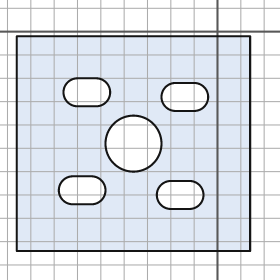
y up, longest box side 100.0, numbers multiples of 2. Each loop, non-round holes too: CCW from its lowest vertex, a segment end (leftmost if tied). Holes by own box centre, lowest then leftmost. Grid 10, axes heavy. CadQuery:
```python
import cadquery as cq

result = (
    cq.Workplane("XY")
    .moveTo(-86.0, -94.0)
    .lineTo(14.0, -94.0)
    .lineTo(14.0, -2.0)
    .lineTo(-86.0, -2.0)
    .close()
    .moveTo(-20.0, -76.0)
    .lineTo(-12.0, -76.0)
    .threePointArc((-6.0, -70.0), (-12.0, -64.0))
    .lineTo(-20.0, -64.0)
    .threePointArc((-26.0, -70.0), (-20.0, -76.0))
    .close()
    .moveTo(-62.0, -74.0)
    .lineTo(-54.0, -74.0)
    .threePointArc((-48.0, -68.0), (-54.0, -62.0))
    .lineTo(-62.0, -62.0)
    .threePointArc((-68.0, -68.0), (-62.0, -74.0))
    .close()
    .moveTo(-36.0, -48.0)
    .circle(12.0)
    .moveTo(-18.0, -34.0)
    .lineTo(-10.0, -34.0)
    .threePointArc((-4.0, -28.0), (-10.0, -22.0))
    .lineTo(-18.0, -22.0)
    .threePointArc((-24.0, -28.0), (-18.0, -34.0))
    .close()
    .moveTo(-60.0, -32.0)
    .lineTo(-52.0, -32.0)
    .threePointArc((-46.0, -26.0), (-52.0, -20.0))
    .lineTo(-60.0, -20.0)
    .threePointArc((-66.0, -26.0), (-60.0, -32.0))
    .close()
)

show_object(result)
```